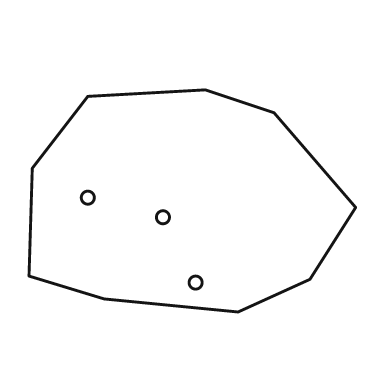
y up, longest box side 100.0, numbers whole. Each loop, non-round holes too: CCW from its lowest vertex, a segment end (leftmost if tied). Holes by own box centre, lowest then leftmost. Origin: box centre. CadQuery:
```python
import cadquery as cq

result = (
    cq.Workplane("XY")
    .moveTo(14.0, -34.0)
    .lineTo(36.0, -24.0)
    .lineTo(50.0, -2.0)
    .lineTo(25.0, 27.0)
    .lineTo(4.0, 34.0)
    .lineTo(-32.0, 32.0)
    .lineTo(-49.0, 10.0)
    .lineTo(-50.0, -23.0)
    .lineTo(-27.0, -30.0)
    .close()
    .moveTo(1.0, -25.0)
    .circle(2.0)
    .moveTo(-9.0, -5.0)
    .circle(2.0)
    .moveTo(-32.0, 1.0)
    .circle(2.0)
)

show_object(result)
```